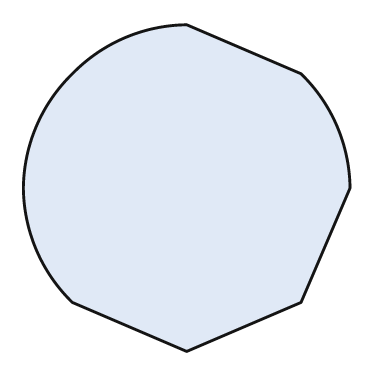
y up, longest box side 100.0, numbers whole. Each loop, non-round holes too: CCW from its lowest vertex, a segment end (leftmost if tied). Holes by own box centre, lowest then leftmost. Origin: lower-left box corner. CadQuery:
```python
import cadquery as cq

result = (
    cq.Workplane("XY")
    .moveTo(50.0, 0.0)
    .lineTo(85.0, 15.0)
    .lineTo(100.0, 50.0)
    .threePointArc((96.0, 69.0), (85.0, 85.0))
    .lineTo(50.0, 100.0)
    .threePointArc((31.0, 96.0), (15.0, 85.0))
    .threePointArc((4.0, 69.0), (0.0, 50.0))
    .threePointArc((4.0, 31.0), (15.0, 15.0))
    .close()
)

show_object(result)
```